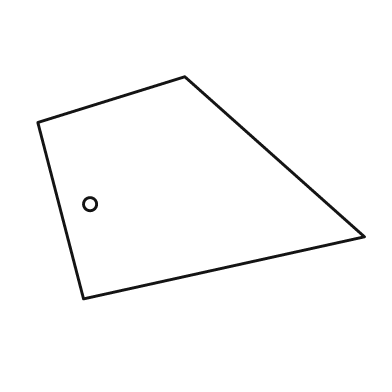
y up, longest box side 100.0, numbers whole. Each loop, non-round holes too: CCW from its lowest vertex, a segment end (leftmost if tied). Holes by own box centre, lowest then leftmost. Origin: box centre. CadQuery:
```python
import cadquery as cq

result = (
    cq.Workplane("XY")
    .moveTo(-36.0, -34.0)
    .lineTo(50.0, -15.0)
    .lineTo(-5.0, 34.0)
    .lineTo(-50.0, 20.0)
    .close()
    .moveTo(-34.0, -5.0)
    .circle(2.0)
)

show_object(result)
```